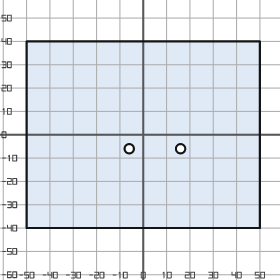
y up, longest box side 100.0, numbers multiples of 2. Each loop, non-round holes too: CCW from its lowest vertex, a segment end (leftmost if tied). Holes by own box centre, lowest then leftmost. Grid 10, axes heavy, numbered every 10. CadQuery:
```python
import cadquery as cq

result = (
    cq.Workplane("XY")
    .moveTo(-50.0, -40.0)
    .lineTo(50.0, -40.0)
    .lineTo(50.0, 40.0)
    .lineTo(-50.0, 40.0)
    .close()
    .moveTo(-6.0, -6.0)
    .circle(2.0)
    .moveTo(16.0, -6.0)
    .circle(2.0)
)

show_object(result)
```